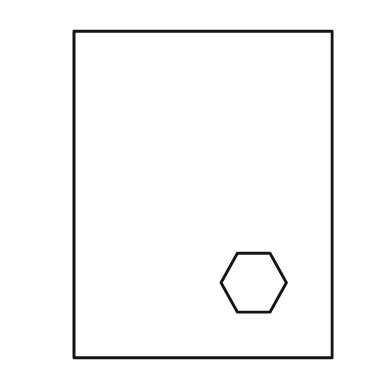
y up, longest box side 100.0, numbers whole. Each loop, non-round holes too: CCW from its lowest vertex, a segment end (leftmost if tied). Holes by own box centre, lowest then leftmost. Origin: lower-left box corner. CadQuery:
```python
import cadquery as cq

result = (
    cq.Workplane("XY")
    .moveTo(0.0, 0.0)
    .lineTo(79.0, 0.0)
    .lineTo(79.0, 100.0)
    .lineTo(0.0, 100.0)
    .close()
    .moveTo(50.0, 14.0)
    .lineTo(60.0, 14.0)
    .lineTo(65.0, 23.0)
    .lineTo(60.0, 32.0)
    .lineTo(50.0, 32.0)
    .lineTo(45.0, 23.0)
    .close()
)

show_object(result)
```